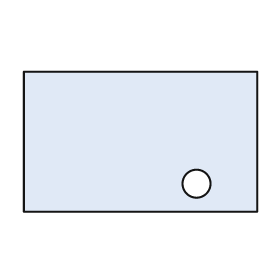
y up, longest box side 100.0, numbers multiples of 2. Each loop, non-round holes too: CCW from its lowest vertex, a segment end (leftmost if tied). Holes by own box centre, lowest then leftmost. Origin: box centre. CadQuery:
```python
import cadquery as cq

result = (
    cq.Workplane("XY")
    .moveTo(-50.0, -30.0)
    .lineTo(50.0, -30.0)
    .lineTo(50.0, 30.0)
    .lineTo(-50.0, 30.0)
    .close()
    .moveTo(24.0, -18.0)
    .circle(6.0)
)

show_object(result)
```